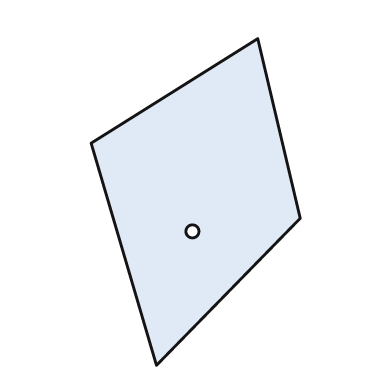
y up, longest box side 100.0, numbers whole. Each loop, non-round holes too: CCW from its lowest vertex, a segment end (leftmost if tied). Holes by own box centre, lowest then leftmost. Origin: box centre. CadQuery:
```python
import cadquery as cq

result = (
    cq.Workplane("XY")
    .moveTo(-12.0, -50.0)
    .lineTo(32.0, -5.0)
    .lineTo(19.0, 50.0)
    .lineTo(-32.0, 18.0)
    .close()
    .moveTo(-1.0, -9.0)
    .circle(2.0)
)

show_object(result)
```